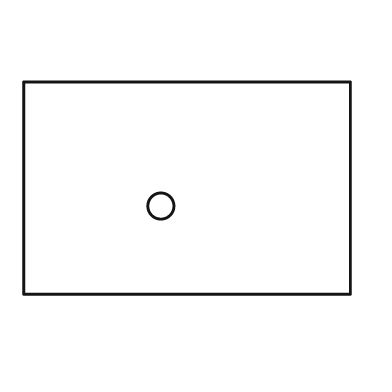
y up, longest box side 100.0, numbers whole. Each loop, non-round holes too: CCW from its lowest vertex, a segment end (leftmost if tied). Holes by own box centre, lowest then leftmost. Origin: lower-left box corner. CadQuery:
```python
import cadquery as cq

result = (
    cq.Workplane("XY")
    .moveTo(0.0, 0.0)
    .lineTo(100.0, 0.0)
    .lineTo(100.0, 65.0)
    .lineTo(0.0, 65.0)
    .close()
    .moveTo(42.0, 27.0)
    .circle(4.0)
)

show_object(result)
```